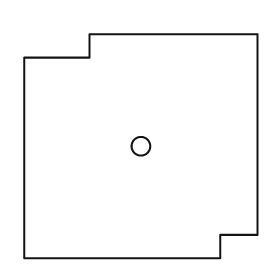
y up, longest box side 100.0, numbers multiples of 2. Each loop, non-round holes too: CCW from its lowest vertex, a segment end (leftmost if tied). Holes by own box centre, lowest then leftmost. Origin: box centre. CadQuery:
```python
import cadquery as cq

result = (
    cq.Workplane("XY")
    .moveTo(-50.0, -48.0)
    .lineTo(34.0, -48.0)
    .lineTo(34.0, -38.0)
    .lineTo(50.0, -38.0)
    .lineTo(50.0, 48.0)
    .lineTo(-22.0, 48.0)
    .lineTo(-22.0, 38.0)
    .lineTo(-50.0, 38.0)
    .close()
    .moveTo(0.0, 0.0)
    .circle(4.0)
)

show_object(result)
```